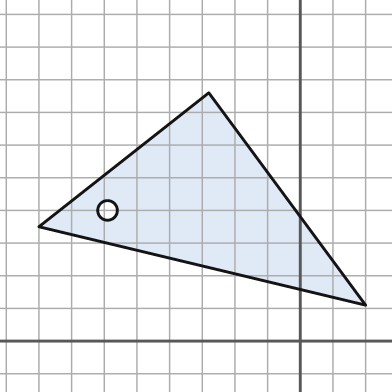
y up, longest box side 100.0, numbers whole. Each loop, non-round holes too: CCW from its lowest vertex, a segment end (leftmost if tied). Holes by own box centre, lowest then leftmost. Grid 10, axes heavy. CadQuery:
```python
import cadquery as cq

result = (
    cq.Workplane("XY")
    .moveTo(20.0, 11.0)
    .lineTo(-28.0, 76.0)
    .lineTo(-80.0, 35.0)
    .close()
    .moveTo(-59.0, 40.0)
    .circle(3.0)
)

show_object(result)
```